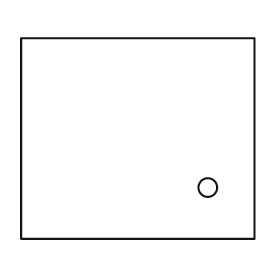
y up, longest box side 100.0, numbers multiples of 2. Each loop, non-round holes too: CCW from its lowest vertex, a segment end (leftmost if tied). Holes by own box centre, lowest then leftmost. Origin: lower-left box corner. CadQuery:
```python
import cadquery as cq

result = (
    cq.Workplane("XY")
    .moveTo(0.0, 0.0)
    .lineTo(100.0, 0.0)
    .lineTo(100.0, 86.0)
    .lineTo(0.0, 86.0)
    .close()
    .moveTo(80.0, 22.0)
    .circle(4.0)
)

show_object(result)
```